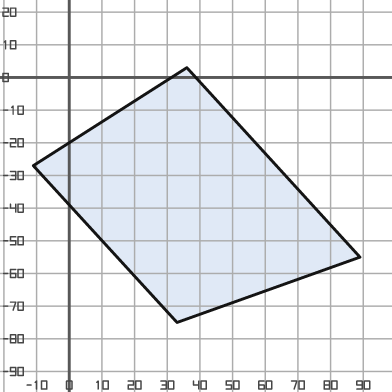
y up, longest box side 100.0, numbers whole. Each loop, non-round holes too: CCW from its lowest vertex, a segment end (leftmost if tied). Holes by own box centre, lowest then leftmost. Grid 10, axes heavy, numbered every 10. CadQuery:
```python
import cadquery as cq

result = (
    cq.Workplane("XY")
    .moveTo(33.0, -75.0)
    .lineTo(89.0, -55.0)
    .lineTo(36.0, 3.0)
    .lineTo(-11.0, -27.0)
    .close()
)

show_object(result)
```